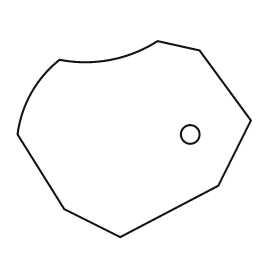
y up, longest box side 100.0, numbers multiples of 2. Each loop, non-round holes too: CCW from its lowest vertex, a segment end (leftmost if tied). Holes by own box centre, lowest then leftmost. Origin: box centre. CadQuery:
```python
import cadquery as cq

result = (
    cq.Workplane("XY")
    .moveTo(-6.0, -42.0)
    .lineTo(36.0, -20.0)
    .lineTo(50.0, 8.0)
    .lineTo(28.0, 38.0)
    .lineTo(10.0, 42.0)
    .threePointArc((-10.0, 34.0), (-32.0, 34.0))
    .threePointArc((-44.0, 20.0), (-50.0, 2.0))
    .lineTo(-30.0, -30.0)
    .close()
    .moveTo(24.0, 2.0)
    .circle(4.0)
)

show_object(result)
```